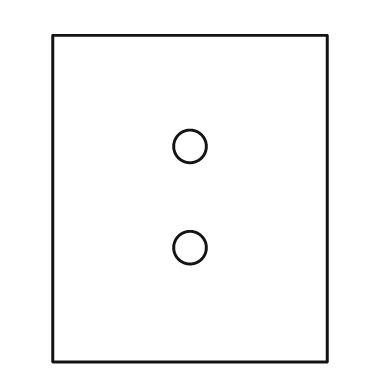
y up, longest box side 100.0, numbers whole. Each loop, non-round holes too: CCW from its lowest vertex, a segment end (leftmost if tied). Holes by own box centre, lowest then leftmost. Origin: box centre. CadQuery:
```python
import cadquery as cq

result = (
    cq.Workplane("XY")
    .moveTo(-42.0, -50.0)
    .lineTo(42.0, -50.0)
    .lineTo(42.0, 50.0)
    .lineTo(-42.0, 50.0)
    .close()
    .moveTo(0.0, -15.0)
    .circle(5.0)
    .moveTo(0.0, 16.0)
    .circle(5.0)
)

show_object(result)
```